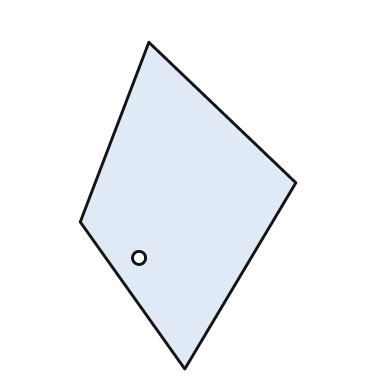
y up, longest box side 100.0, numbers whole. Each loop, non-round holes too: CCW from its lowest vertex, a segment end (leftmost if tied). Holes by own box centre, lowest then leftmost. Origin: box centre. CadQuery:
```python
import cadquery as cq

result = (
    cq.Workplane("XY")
    .moveTo(-1.0, -50.0)
    .lineTo(33.0, 7.0)
    .lineTo(-12.0, 50.0)
    .lineTo(-33.0, -5.0)
    .close()
    .moveTo(-15.0, -16.0)
    .circle(2.0)
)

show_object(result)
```